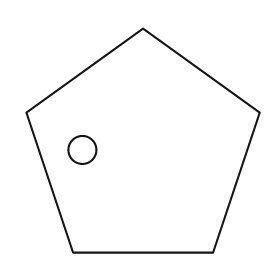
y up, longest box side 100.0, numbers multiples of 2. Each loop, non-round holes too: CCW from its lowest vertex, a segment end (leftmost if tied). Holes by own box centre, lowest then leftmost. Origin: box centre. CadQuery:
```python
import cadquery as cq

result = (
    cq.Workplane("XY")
    .moveTo(-30.0, -48.0)
    .lineTo(30.0, -48.0)
    .lineTo(50.0, 12.0)
    .lineTo(0.0, 48.0)
    .lineTo(-50.0, 12.0)
    .close()
    .moveTo(-26.0, -4.0)
    .circle(6.0)
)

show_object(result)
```